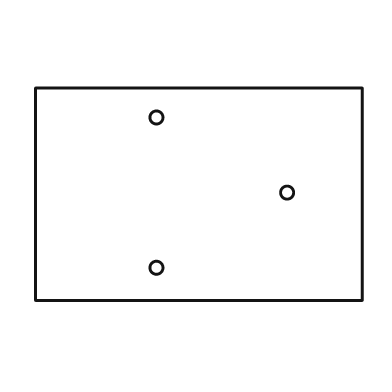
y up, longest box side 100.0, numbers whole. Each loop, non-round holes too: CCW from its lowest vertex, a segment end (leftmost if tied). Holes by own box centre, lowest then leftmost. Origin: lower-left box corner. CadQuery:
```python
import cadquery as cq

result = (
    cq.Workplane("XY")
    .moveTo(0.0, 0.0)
    .lineTo(100.0, 0.0)
    .lineTo(100.0, 65.0)
    .lineTo(0.0, 65.0)
    .close()
    .moveTo(37.0, 10.0)
    .circle(2.0)
    .moveTo(77.0, 33.0)
    .circle(2.0)
    .moveTo(37.0, 56.0)
    .circle(2.0)
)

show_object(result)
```